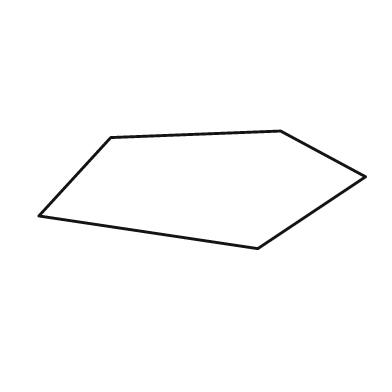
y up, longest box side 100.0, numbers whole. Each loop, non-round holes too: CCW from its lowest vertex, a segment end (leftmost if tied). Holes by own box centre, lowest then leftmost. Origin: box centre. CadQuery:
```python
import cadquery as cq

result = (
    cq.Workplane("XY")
    .moveTo(17.0, -18.0)
    .lineTo(50.0, 4.0)
    .lineTo(24.0, 18.0)
    .lineTo(-28.0, 16.0)
    .lineTo(-50.0, -8.0)
    .close()
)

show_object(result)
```